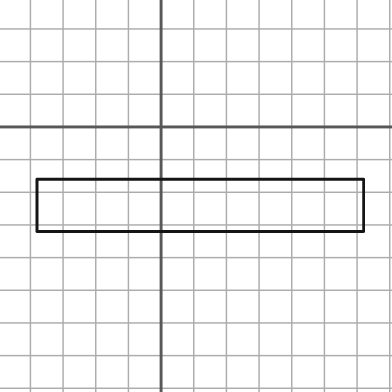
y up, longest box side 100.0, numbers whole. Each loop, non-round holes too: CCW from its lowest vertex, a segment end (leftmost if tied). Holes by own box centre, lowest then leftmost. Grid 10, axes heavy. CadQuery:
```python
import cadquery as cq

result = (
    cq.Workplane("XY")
    .moveTo(-38.0, -32.0)
    .lineTo(62.0, -32.0)
    .lineTo(62.0, -16.0)
    .lineTo(-38.0, -16.0)
    .close()
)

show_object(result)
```